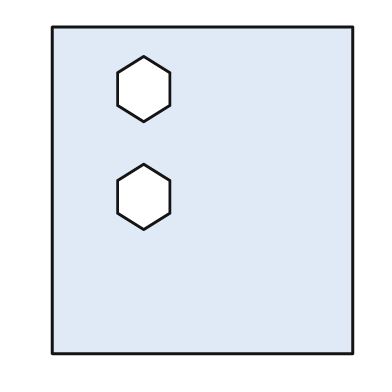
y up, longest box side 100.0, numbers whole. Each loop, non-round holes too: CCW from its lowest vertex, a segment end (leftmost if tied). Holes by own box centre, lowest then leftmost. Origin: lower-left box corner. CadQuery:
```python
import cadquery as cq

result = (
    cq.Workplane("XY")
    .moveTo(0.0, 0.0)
    .lineTo(92.0, 0.0)
    .lineTo(92.0, 100.0)
    .lineTo(0.0, 100.0)
    .close()
    .moveTo(28.0, 38.0)
    .lineTo(36.0, 43.0)
    .lineTo(36.0, 53.0)
    .lineTo(28.0, 58.0)
    .lineTo(20.0, 53.0)
    .lineTo(20.0, 43.0)
    .close()
    .moveTo(28.0, 71.0)
    .lineTo(36.0, 76.0)
    .lineTo(36.0, 86.0)
    .lineTo(28.0, 91.0)
    .lineTo(20.0, 86.0)
    .lineTo(20.0, 76.0)
    .close()
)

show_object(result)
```